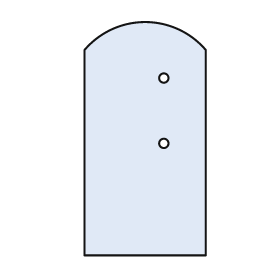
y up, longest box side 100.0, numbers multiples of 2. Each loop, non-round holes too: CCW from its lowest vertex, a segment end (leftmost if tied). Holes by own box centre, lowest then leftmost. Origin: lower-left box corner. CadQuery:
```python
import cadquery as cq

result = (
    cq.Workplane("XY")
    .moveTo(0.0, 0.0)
    .lineTo(52.0, 0.0)
    .lineTo(52.0, 88.0)
    .threePointArc((26.0, 100.0), (0.0, 88.0))
    .close()
    .moveTo(34.0, 48.0)
    .circle(2.0)
    .moveTo(34.0, 76.0)
    .circle(2.0)
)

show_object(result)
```